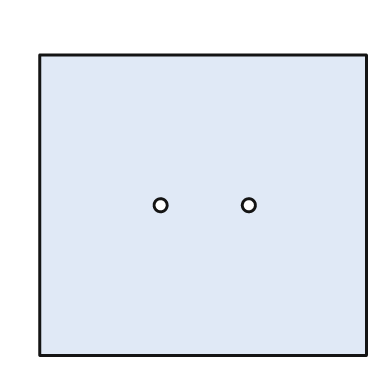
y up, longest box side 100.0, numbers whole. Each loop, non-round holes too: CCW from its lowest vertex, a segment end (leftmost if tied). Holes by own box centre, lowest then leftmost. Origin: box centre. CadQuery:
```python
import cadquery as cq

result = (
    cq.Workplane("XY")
    .moveTo(-50.0, -46.0)
    .lineTo(50.0, -46.0)
    .lineTo(50.0, 46.0)
    .lineTo(-50.0, 46.0)
    .close()
    .moveTo(-13.0, 0.0)
    .circle(2.0)
    .moveTo(14.0, 0.0)
    .circle(2.0)
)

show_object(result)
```